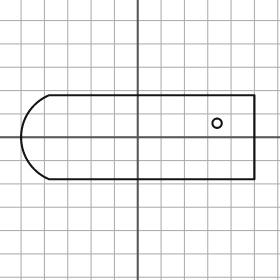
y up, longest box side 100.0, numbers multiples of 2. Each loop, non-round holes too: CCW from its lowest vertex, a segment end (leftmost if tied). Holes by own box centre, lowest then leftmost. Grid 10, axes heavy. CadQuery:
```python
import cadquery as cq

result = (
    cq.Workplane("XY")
    .moveTo(-38.0, -18.0)
    .lineTo(50.0, -18.0)
    .lineTo(50.0, 18.0)
    .lineTo(-38.0, 18.0)
    .threePointArc((-50.0, 0.0), (-38.0, -18.0))
    .close()
    .moveTo(34.0, 6.0)
    .circle(2.0)
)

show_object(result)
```